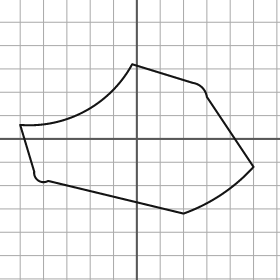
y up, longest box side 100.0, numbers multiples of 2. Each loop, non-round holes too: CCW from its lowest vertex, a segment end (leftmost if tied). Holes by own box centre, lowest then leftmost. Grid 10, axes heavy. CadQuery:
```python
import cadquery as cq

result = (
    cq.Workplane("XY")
    .moveTo(20.0, -32.0)
    .threePointArc((36.0, -24.0), (50.0, -12.0))
    .lineTo(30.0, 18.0)
    .threePointArc((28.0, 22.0), (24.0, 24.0))
    .lineTo(-2.0, 32.0)
    .threePointArc((-22.0, 12.0), (-50.0, 6.0))
    .lineTo(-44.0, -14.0)
    .threePointArc((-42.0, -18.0), (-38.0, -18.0))
    .close()
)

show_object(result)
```